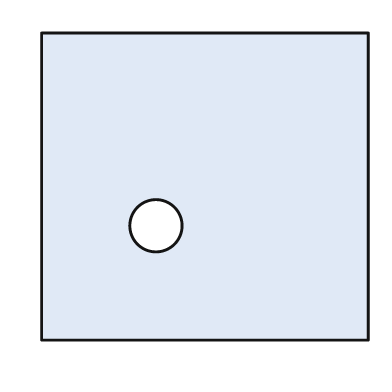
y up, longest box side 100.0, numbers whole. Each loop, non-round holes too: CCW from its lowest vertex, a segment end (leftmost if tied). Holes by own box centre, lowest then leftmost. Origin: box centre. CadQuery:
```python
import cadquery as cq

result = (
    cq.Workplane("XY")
    .moveTo(-50.0, -47.0)
    .lineTo(50.0, -47.0)
    .lineTo(50.0, 47.0)
    .lineTo(-50.0, 47.0)
    .close()
    .moveTo(-15.0, -12.0)
    .circle(8.0)
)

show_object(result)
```